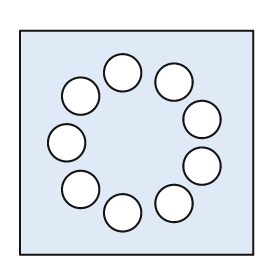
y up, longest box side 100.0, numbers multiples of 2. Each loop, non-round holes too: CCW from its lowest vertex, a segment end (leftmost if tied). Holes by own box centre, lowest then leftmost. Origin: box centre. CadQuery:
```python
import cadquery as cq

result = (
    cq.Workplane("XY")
    .moveTo(-50.0, -48.0)
    .lineTo(50.0, -48.0)
    .lineTo(50.0, 48.0)
    .lineTo(-50.0, 48.0)
    .close()
    .moveTo(-6.0, -30.0)
    .circle(8.0)
    .moveTo(16.0, -26.0)
    .circle(8.0)
    .moveTo(-24.0, -20.0)
    .circle(8.0)
    .moveTo(28.0, -10.0)
    .circle(8.0)
    .moveTo(-30.0, 0.0)
    .circle(8.0)
    .moveTo(28.0, 10.0)
    .circle(8.0)
    .moveTo(-24.0, 20.0)
    .circle(8.0)
    .moveTo(16.0, 26.0)
    .circle(8.0)
    .moveTo(-6.0, 30.0)
    .circle(8.0)
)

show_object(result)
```